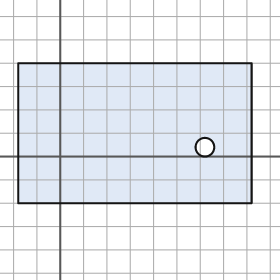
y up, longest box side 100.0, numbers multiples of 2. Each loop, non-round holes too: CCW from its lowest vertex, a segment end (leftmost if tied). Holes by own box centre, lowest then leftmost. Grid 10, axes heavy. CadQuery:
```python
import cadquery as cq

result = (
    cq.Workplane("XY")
    .moveTo(-18.0, -20.0)
    .lineTo(82.0, -20.0)
    .lineTo(82.0, 40.0)
    .lineTo(-18.0, 40.0)
    .close()
    .moveTo(62.0, 4.0)
    .circle(4.0)
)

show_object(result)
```